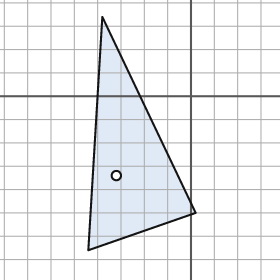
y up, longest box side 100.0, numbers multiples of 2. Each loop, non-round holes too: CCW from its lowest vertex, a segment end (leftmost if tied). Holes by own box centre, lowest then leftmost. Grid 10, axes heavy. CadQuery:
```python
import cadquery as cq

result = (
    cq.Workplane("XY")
    .moveTo(-44.0, -66.0)
    .lineTo(2.0, -50.0)
    .lineTo(-38.0, 34.0)
    .close()
    .moveTo(-32.0, -34.0)
    .circle(2.0)
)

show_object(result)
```